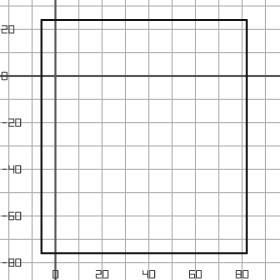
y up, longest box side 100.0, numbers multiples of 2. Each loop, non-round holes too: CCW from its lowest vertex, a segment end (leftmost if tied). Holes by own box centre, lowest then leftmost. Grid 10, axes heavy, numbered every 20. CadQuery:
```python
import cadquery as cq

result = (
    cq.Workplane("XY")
    .moveTo(-6.0, -76.0)
    .lineTo(82.0, -76.0)
    .lineTo(82.0, 24.0)
    .lineTo(-6.0, 24.0)
    .close()
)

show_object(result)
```